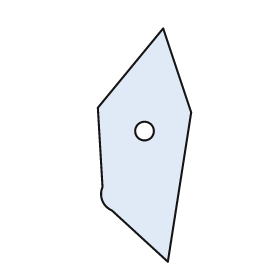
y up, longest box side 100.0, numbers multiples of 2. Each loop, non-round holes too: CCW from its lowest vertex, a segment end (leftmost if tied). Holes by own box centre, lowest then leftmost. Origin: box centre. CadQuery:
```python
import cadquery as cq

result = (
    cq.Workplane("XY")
    .moveTo(10.0, -50.0)
    .lineTo(20.0, 14.0)
    .lineTo(8.0, 50.0)
    .lineTo(-20.0, 16.0)
    .lineTo(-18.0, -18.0)
    .threePointArc((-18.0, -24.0), (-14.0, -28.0))
    .close()
    .moveTo(0.0, 6.0)
    .circle(4.0)
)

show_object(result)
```